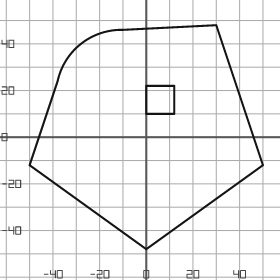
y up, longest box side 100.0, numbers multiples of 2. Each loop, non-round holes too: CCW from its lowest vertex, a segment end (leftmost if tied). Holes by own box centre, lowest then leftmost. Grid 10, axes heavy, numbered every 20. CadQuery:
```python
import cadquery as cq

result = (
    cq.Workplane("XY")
    .moveTo(0.0, -48.0)
    .lineTo(50.0, -12.0)
    .lineTo(30.0, 48.0)
    .lineTo(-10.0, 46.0)
    .threePointArc((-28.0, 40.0), (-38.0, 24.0))
    .lineTo(-50.0, -12.0)
    .close()
    .moveTo(0.0, 10.0)
    .lineTo(12.0, 10.0)
    .lineTo(12.0, 22.0)
    .lineTo(0.0, 22.0)
    .close()
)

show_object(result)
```